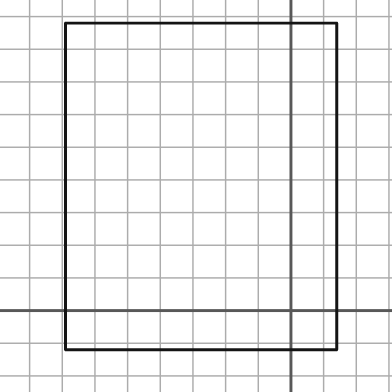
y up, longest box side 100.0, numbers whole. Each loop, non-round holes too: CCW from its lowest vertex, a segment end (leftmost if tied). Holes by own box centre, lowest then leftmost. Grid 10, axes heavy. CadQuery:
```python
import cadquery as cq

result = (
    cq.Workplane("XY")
    .moveTo(-69.0, -12.0)
    .lineTo(14.0, -12.0)
    .lineTo(14.0, 88.0)
    .lineTo(-69.0, 88.0)
    .close()
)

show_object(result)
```